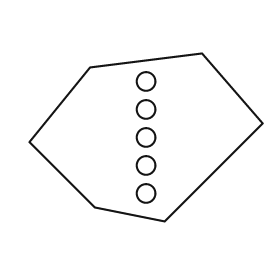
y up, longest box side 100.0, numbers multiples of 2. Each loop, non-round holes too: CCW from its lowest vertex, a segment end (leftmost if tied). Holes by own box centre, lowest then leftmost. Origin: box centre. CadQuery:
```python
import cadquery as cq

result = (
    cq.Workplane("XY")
    .moveTo(8.0, -36.0)
    .lineTo(50.0, 6.0)
    .lineTo(24.0, 36.0)
    .lineTo(-24.0, 30.0)
    .lineTo(-50.0, -2.0)
    .lineTo(-22.0, -30.0)
    .close()
    .moveTo(0.0, -24.0)
    .circle(4.0)
    .moveTo(0.0, -12.0)
    .circle(4.0)
    .moveTo(0.0, 0.0)
    .circle(4.0)
    .moveTo(0.0, 12.0)
    .circle(4.0)
    .moveTo(0.0, 24.0)
    .circle(4.0)
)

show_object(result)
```